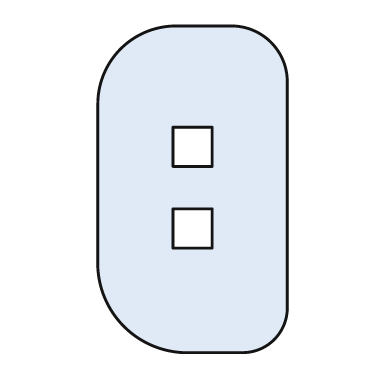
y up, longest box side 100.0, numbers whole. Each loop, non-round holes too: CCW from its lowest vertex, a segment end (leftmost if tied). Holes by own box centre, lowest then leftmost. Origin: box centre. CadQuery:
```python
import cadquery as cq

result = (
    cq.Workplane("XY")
    .moveTo(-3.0, -50.0)
    .lineTo(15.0, -50.0)
    .threePointArc((25.0, -46.0), (29.0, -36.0))
    .lineTo(29.0, 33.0)
    .threePointArc((24.0, 45.0), (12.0, 50.0))
    .lineTo(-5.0, 50.0)
    .threePointArc((-22.0, 43.0), (-29.0, 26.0))
    .lineTo(-29.0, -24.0)
    .threePointArc((-21.0, -42.0), (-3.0, -50.0))
    .close()
    .moveTo(-6.0, -18.0)
    .lineTo(6.0, -18.0)
    .lineTo(6.0, -6.0)
    .lineTo(-6.0, -6.0)
    .close()
    .moveTo(-6.0, 7.0)
    .lineTo(6.0, 7.0)
    .lineTo(6.0, 19.0)
    .lineTo(-6.0, 19.0)
    .close()
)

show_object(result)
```